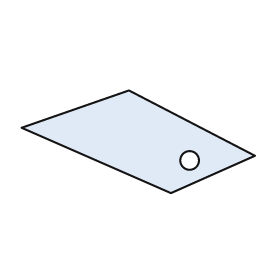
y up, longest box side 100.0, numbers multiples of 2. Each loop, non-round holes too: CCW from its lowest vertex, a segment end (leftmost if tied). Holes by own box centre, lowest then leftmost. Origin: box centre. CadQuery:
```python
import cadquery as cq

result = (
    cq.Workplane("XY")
    .moveTo(14.0, -22.0)
    .lineTo(50.0, -6.0)
    .lineTo(-4.0, 22.0)
    .lineTo(-50.0, 6.0)
    .close()
    .moveTo(22.0, -8.0)
    .circle(4.0)
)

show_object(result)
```